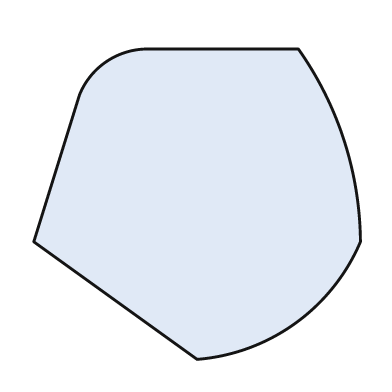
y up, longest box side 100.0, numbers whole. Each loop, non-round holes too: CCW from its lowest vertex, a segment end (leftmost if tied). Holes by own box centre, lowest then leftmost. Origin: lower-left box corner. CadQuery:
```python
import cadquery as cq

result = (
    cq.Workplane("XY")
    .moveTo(50.0, 0.0)
    .threePointArc((80.0, 11.0), (100.0, 36.0))
    .threePointArc((95.0, 67.0), (81.0, 95.0))
    .lineTo(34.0, 95.0)
    .threePointArc((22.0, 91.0), (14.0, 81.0))
    .lineTo(0.0, 36.0)
    .close()
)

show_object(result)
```